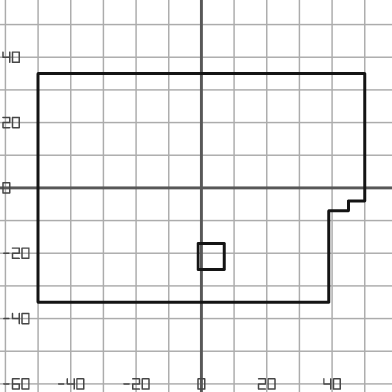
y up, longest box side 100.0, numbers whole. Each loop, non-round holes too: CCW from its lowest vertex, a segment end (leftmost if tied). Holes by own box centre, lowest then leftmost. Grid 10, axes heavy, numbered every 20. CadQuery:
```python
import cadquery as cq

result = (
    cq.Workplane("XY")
    .moveTo(-50.0, -35.0)
    .lineTo(39.0, -35.0)
    .lineTo(39.0, -7.0)
    .lineTo(45.0, -7.0)
    .lineTo(45.0, -4.0)
    .lineTo(50.0, -4.0)
    .lineTo(50.0, 35.0)
    .lineTo(-50.0, 35.0)
    .close()
    .moveTo(-1.0, -25.0)
    .lineTo(7.0, -25.0)
    .lineTo(7.0, -17.0)
    .lineTo(-1.0, -17.0)
    .close()
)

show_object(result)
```